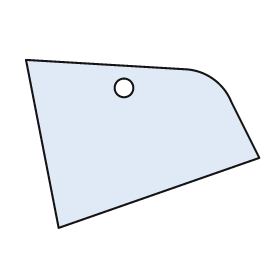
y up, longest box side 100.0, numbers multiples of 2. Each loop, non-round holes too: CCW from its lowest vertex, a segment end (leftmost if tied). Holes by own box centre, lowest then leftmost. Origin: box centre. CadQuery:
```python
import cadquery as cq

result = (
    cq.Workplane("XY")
    .moveTo(-36.0, -36.0)
    .lineTo(50.0, -6.0)
    .lineTo(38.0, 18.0)
    .threePointArc((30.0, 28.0), (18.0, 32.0))
    .lineTo(-50.0, 36.0)
    .close()
    .moveTo(-8.0, 24.0)
    .circle(4.0)
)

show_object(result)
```